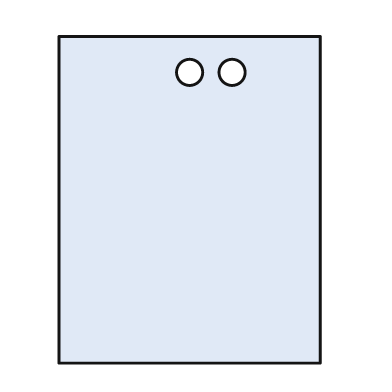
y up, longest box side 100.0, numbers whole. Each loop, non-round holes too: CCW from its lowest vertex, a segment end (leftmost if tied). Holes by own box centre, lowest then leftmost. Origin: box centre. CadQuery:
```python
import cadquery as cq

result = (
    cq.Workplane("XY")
    .moveTo(-40.0, -50.0)
    .lineTo(40.0, -50.0)
    .lineTo(40.0, 50.0)
    .lineTo(-40.0, 50.0)
    .close()
    .moveTo(0.0, 39.0)
    .circle(4.0)
    .moveTo(13.0, 39.0)
    .circle(4.0)
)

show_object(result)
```